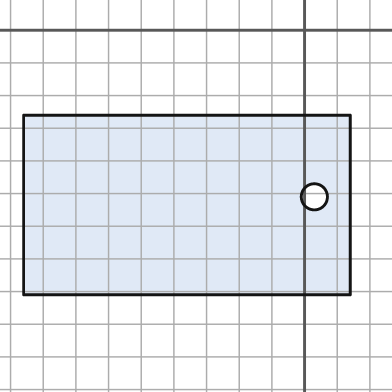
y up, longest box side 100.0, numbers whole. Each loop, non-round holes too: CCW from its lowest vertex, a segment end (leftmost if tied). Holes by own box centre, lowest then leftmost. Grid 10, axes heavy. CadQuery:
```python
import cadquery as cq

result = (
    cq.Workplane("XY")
    .moveTo(-86.0, -81.0)
    .lineTo(14.0, -81.0)
    .lineTo(14.0, -26.0)
    .lineTo(-86.0, -26.0)
    .close()
    .moveTo(3.0, -51.0)
    .circle(4.0)
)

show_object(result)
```